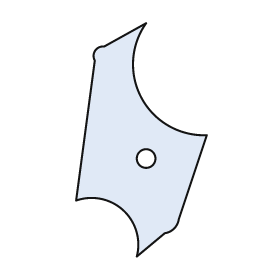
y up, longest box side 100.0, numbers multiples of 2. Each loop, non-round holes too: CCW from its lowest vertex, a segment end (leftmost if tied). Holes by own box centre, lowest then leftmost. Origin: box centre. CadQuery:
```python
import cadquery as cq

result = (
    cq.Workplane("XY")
    .moveTo(-2.0, -50.0)
    .lineTo(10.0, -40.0)
    .threePointArc((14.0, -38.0), (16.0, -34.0))
    .lineTo(28.0, 2.0)
    .threePointArc((0.0, 18.0), (2.0, 50.0))
    .lineTo(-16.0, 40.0)
    .threePointArc((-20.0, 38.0), (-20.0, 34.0))
    .lineTo(-28.0, -26.0)
    .threePointArc((-8.0, -30.0), (-2.0, -50.0))
    .close()
    .moveTo(2.0, -8.0)
    .circle(4.0)
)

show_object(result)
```